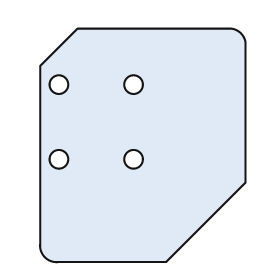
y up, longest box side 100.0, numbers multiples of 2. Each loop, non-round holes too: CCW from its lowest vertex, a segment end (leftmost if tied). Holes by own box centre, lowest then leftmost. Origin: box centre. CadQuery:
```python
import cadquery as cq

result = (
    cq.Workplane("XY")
    .moveTo(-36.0, -50.0)
    .lineTo(10.0, -50.0)
    .lineTo(44.0, -16.0)
    .lineTo(44.0, 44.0)
    .threePointArc((42.0, 48.0), (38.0, 50.0))
    .lineTo(-28.0, 50.0)
    .lineTo(-44.0, 34.0)
    .lineTo(-44.0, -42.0)
    .threePointArc((-42.0, -48.0), (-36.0, -50.0))
    .close()
    .moveTo(-36.0, -6.0)
    .circle(4.0)
    .moveTo(-4.0, -6.0)
    .circle(4.0)
    .moveTo(-36.0, 26.0)
    .circle(4.0)
    .moveTo(-4.0, 26.0)
    .circle(4.0)
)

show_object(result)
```